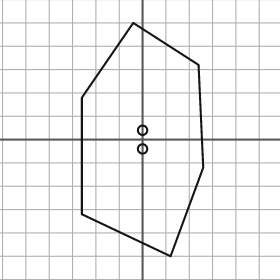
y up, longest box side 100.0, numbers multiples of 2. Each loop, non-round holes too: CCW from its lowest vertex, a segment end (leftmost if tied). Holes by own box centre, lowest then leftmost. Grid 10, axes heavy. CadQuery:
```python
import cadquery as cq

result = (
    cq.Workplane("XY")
    .moveTo(12.0, -50.0)
    .lineTo(26.0, -12.0)
    .lineTo(24.0, 32.0)
    .lineTo(-4.0, 50.0)
    .lineTo(-26.0, 18.0)
    .lineTo(-26.0, -32.0)
    .close()
    .moveTo(0.0, -4.0)
    .circle(2.0)
    .moveTo(0.0, 4.0)
    .circle(2.0)
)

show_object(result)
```